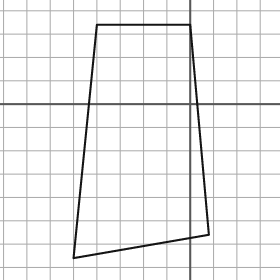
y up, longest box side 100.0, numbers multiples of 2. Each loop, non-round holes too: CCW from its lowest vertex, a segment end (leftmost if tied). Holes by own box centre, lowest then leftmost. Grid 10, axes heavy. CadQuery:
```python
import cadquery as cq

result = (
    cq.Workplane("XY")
    .moveTo(-50.0, -66.0)
    .lineTo(8.0, -56.0)
    .lineTo(0.0, 34.0)
    .lineTo(-40.0, 34.0)
    .close()
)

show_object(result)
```